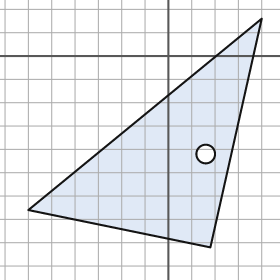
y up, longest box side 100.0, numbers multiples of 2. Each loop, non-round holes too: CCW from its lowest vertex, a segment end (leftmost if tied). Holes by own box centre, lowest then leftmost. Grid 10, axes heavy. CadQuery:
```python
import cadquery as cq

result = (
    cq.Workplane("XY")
    .moveTo(18.0, -82.0)
    .lineTo(40.0, 16.0)
    .lineTo(-60.0, -66.0)
    .close()
    .moveTo(16.0, -42.0)
    .circle(4.0)
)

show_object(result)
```